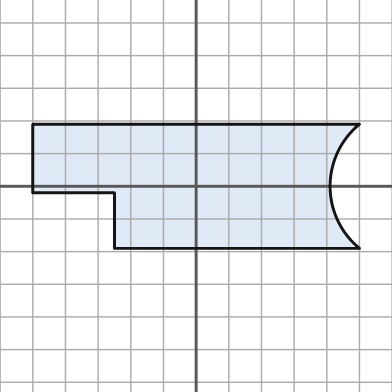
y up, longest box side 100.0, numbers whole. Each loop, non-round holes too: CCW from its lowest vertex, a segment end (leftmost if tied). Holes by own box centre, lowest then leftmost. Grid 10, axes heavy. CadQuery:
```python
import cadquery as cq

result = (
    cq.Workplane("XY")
    .moveTo(-25.0, -19.0)
    .lineTo(50.0, -19.0)
    .threePointArc((41.0, 0.0), (50.0, 19.0))
    .lineTo(-50.0, 19.0)
    .lineTo(-50.0, -2.0)
    .lineTo(-25.0, -2.0)
    .close()
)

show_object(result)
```